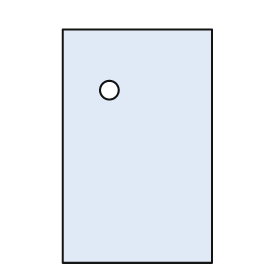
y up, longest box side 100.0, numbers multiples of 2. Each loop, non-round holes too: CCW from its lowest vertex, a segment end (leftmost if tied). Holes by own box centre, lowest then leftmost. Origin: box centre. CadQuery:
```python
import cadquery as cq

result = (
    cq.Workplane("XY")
    .moveTo(-32.0, -50.0)
    .lineTo(32.0, -50.0)
    .lineTo(32.0, 50.0)
    .lineTo(-32.0, 50.0)
    .close()
    .moveTo(-12.0, 24.0)
    .circle(4.0)
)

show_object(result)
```